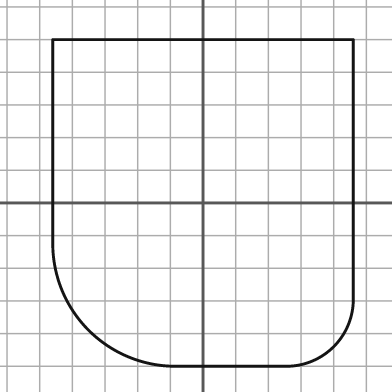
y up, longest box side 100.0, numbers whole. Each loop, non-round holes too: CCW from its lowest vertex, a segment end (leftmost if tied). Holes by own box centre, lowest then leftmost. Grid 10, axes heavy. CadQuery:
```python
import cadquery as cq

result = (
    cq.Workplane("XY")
    .moveTo(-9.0, -50.0)
    .lineTo(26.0, -50.0)
    .threePointArc((40.0, -44.0), (46.0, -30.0))
    .lineTo(46.0, 50.0)
    .lineTo(-46.0, 50.0)
    .lineTo(-46.0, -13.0)
    .threePointArc((-35.0, -39.0), (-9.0, -50.0))
    .close()
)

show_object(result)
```